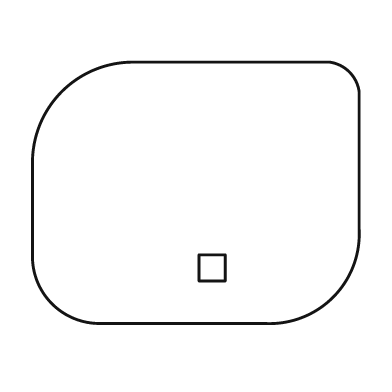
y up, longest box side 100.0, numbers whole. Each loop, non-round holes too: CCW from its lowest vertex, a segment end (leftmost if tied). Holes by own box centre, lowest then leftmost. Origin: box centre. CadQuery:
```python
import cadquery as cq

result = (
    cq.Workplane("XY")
    .moveTo(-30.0, -40.0)
    .lineTo(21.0, -40.0)
    .threePointArc((42.0, -32.0), (50.0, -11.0))
    .lineTo(50.0, 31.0)
    .threePointArc((47.0, 37.0), (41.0, 40.0))
    .lineTo(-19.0, 40.0)
    .threePointArc((-41.0, 31.0), (-50.0, 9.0))
    .lineTo(-50.0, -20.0)
    .threePointArc((-44.0, -34.0), (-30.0, -40.0))
    .close()
    .moveTo(1.0, -27.0)
    .lineTo(9.0, -27.0)
    .lineTo(9.0, -19.0)
    .lineTo(1.0, -19.0)
    .close()
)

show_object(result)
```